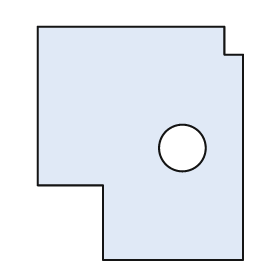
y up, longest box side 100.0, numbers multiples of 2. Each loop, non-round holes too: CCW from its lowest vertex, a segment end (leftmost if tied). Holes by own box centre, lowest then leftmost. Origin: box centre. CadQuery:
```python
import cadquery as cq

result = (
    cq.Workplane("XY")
    .moveTo(-16.0, -50.0)
    .lineTo(44.0, -50.0)
    .lineTo(44.0, 38.0)
    .lineTo(36.0, 38.0)
    .lineTo(36.0, 50.0)
    .lineTo(-44.0, 50.0)
    .lineTo(-44.0, -18.0)
    .lineTo(-16.0, -18.0)
    .close()
    .moveTo(18.0, -2.0)
    .circle(10.0)
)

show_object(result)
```